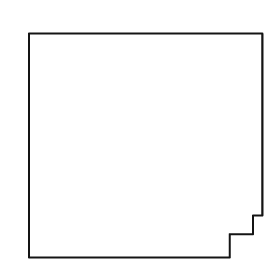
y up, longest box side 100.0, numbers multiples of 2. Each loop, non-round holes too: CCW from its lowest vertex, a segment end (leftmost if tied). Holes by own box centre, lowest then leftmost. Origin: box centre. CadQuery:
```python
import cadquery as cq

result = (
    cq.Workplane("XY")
    .moveTo(-50.0, -48.0)
    .lineTo(36.0, -48.0)
    .lineTo(36.0, -38.0)
    .lineTo(46.0, -38.0)
    .lineTo(46.0, -30.0)
    .lineTo(50.0, -30.0)
    .lineTo(50.0, 48.0)
    .lineTo(-50.0, 48.0)
    .close()
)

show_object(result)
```